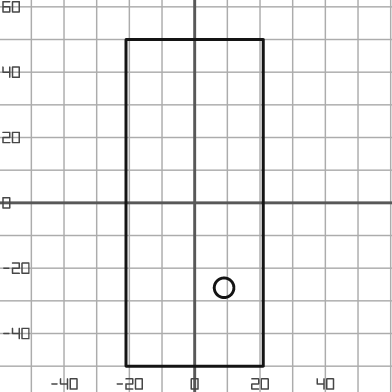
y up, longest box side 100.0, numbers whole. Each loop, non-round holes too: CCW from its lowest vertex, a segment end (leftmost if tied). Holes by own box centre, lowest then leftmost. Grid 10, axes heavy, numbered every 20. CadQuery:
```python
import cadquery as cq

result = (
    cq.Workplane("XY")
    .moveTo(-21.0, -50.0)
    .lineTo(21.0, -50.0)
    .lineTo(21.0, 50.0)
    .lineTo(-21.0, 50.0)
    .close()
    .moveTo(9.0, -26.0)
    .circle(3.0)
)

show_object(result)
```